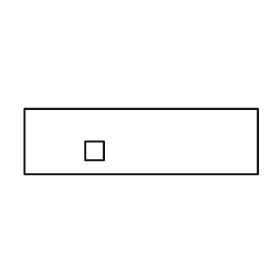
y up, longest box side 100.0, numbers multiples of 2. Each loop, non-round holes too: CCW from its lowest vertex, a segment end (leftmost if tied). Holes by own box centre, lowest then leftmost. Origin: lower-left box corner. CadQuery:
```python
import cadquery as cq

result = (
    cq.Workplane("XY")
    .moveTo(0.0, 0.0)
    .lineTo(100.0, 0.0)
    .lineTo(100.0, 28.0)
    .lineTo(0.0, 28.0)
    .close()
    .moveTo(26.0, 6.0)
    .lineTo(34.0, 6.0)
    .lineTo(34.0, 14.0)
    .lineTo(26.0, 14.0)
    .close()
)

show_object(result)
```